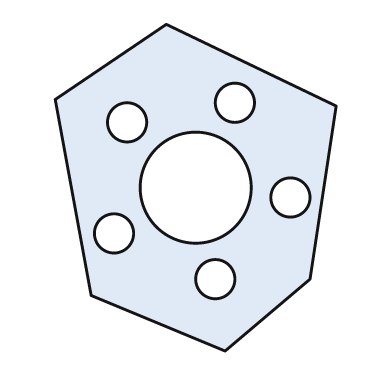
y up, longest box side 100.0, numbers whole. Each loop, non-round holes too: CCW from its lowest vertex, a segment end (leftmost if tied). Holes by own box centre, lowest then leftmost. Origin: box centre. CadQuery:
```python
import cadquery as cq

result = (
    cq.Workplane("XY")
    .moveTo(9.0, -50.0)
    .lineTo(35.0, -28.0)
    .lineTo(43.0, 25.0)
    .lineTo(-9.0, 50.0)
    .lineTo(-43.0, 27.0)
    .lineTo(-32.0, -33.0)
    .close()
    .moveTo(6.0, -28.0)
    .circle(6.0)
    .moveTo(-25.0, -14.0)
    .circle(6.0)
    .moveTo(29.0, -3.0)
    .circle(6.0)
    .moveTo(0.0, 0.0)
    .circle(17.0)
    .moveTo(-21.0, 20.0)
    .circle(6.0)
    .moveTo(12.0, 26.0)
    .circle(6.0)
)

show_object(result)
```